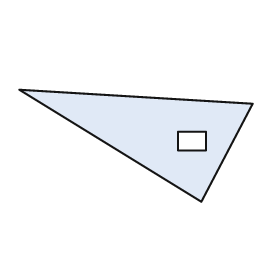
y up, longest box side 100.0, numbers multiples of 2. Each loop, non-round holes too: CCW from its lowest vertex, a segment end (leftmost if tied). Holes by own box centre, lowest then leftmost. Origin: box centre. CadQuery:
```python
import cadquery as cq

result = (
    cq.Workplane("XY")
    .moveTo(28.0, -24.0)
    .lineTo(50.0, 18.0)
    .lineTo(-50.0, 24.0)
    .close()
    .moveTo(18.0, -2.0)
    .lineTo(30.0, -2.0)
    .lineTo(30.0, 6.0)
    .lineTo(18.0, 6.0)
    .close()
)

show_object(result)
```